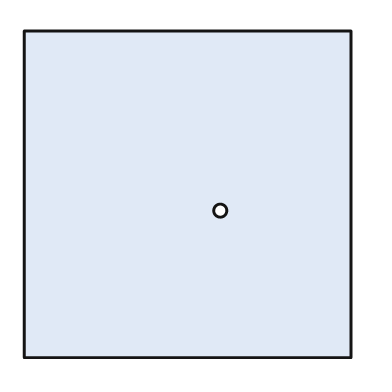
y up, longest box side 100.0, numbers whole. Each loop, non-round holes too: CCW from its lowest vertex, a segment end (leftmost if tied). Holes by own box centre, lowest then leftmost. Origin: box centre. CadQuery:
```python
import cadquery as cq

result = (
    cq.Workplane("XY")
    .moveTo(-50.0, -50.0)
    .lineTo(50.0, -50.0)
    .lineTo(50.0, 50.0)
    .lineTo(-50.0, 50.0)
    .close()
    .moveTo(10.0, -5.0)
    .circle(2.0)
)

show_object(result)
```